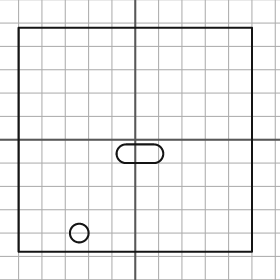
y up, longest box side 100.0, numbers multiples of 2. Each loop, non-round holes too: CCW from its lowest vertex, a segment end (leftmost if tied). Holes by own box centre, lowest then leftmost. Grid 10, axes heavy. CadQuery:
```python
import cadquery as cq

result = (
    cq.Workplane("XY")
    .moveTo(-50.0, -48.0)
    .lineTo(50.0, -48.0)
    .lineTo(50.0, 48.0)
    .lineTo(-50.0, 48.0)
    .close()
    .moveTo(-24.0, -40.0)
    .circle(4.0)
    .moveTo(-4.0, -10.0)
    .lineTo(8.0, -10.0)
    .threePointArc((12.0, -6.0), (8.0, -2.0))
    .lineTo(-4.0, -2.0)
    .threePointArc((-8.0, -6.0), (-4.0, -10.0))
    .close()
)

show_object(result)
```